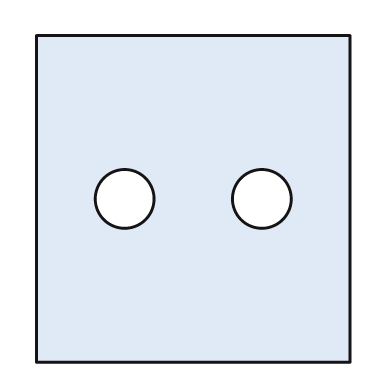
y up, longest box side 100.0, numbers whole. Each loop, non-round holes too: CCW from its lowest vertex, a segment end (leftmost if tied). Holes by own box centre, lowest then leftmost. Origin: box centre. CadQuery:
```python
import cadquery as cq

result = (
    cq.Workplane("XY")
    .moveTo(-48.0, -50.0)
    .lineTo(48.0, -50.0)
    .lineTo(48.0, 50.0)
    .lineTo(-48.0, 50.0)
    .close()
    .moveTo(-21.0, 0.0)
    .circle(9.0)
    .moveTo(21.0, 0.0)
    .circle(9.0)
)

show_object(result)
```